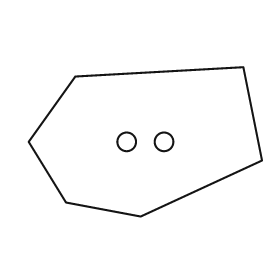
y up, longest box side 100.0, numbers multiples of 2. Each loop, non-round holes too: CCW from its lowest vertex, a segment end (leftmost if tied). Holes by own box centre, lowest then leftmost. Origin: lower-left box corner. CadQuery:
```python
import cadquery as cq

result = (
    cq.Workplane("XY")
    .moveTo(48.0, 0.0)
    .lineTo(100.0, 24.0)
    .lineTo(92.0, 64.0)
    .lineTo(20.0, 60.0)
    .lineTo(0.0, 32.0)
    .lineTo(16.0, 6.0)
    .close()
    .moveTo(42.0, 32.0)
    .circle(4.0)
    .moveTo(58.0, 32.0)
    .circle(4.0)
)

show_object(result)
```